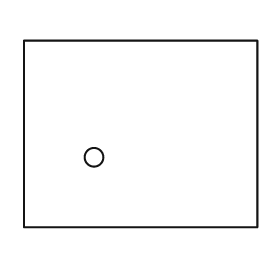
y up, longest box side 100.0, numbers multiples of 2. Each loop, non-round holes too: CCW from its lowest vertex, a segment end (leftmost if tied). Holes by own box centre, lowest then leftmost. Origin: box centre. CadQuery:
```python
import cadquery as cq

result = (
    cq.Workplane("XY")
    .moveTo(-50.0, -40.0)
    .lineTo(50.0, -40.0)
    .lineTo(50.0, 40.0)
    .lineTo(-50.0, 40.0)
    .close()
    .moveTo(-20.0, -10.0)
    .circle(4.0)
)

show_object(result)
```